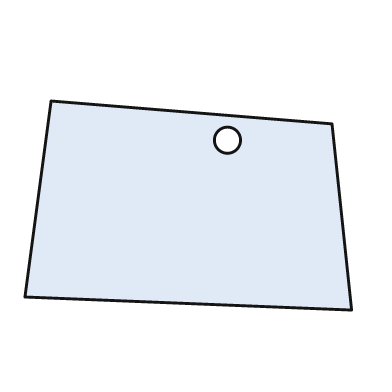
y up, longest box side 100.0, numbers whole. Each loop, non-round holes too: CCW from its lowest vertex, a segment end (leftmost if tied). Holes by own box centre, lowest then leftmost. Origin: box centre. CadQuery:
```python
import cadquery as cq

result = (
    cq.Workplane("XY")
    .moveTo(50.0, -32.0)
    .lineTo(44.0, 25.0)
    .lineTo(-42.0, 32.0)
    .lineTo(-50.0, -28.0)
    .close()
    .moveTo(12.0, 20.0)
    .circle(4.0)
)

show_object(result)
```